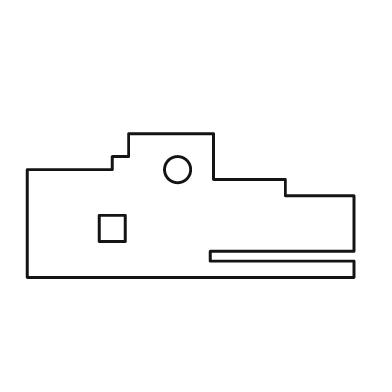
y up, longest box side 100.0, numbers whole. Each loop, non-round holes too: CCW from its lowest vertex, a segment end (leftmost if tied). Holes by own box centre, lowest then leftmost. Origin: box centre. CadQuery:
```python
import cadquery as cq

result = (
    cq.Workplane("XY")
    .moveTo(-50.0, -22.0)
    .lineTo(50.0, -22.0)
    .lineTo(50.0, -17.0)
    .lineTo(6.0, -17.0)
    .lineTo(6.0, -14.0)
    .lineTo(50.0, -14.0)
    .lineTo(50.0, 3.0)
    .lineTo(29.0, 3.0)
    .lineTo(29.0, 8.0)
    .lineTo(7.0, 8.0)
    .lineTo(7.0, 22.0)
    .lineTo(-19.0, 22.0)
    .lineTo(-19.0, 15.0)
    .lineTo(-24.0, 15.0)
    .lineTo(-24.0, 11.0)
    .lineTo(-50.0, 11.0)
    .close()
    .moveTo(-28.0, -11.0)
    .lineTo(-20.0, -11.0)
    .lineTo(-20.0, -3.0)
    .lineTo(-28.0, -3.0)
    .close()
    .moveTo(-4.0, 11.0)
    .circle(4.0)
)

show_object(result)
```